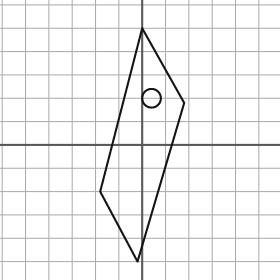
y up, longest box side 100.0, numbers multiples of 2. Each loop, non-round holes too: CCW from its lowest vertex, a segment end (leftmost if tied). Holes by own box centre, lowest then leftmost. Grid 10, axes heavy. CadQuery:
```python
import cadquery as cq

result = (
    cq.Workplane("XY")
    .moveTo(-2.0, -50.0)
    .lineTo(18.0, 18.0)
    .lineTo(0.0, 50.0)
    .lineTo(-18.0, -20.0)
    .close()
    .moveTo(4.0, 20.0)
    .circle(4.0)
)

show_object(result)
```